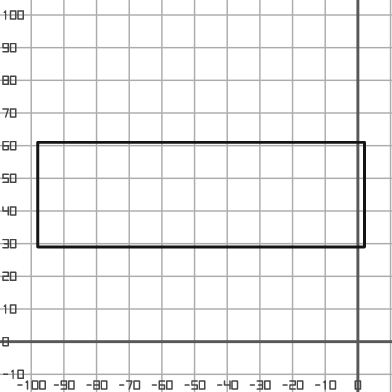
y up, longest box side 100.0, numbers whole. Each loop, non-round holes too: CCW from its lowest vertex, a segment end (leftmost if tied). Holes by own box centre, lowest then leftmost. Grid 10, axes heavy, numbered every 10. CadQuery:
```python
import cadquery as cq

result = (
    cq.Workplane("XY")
    .moveTo(-98.0, 29.0)
    .lineTo(2.0, 29.0)
    .lineTo(2.0, 61.0)
    .lineTo(-98.0, 61.0)
    .close()
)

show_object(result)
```